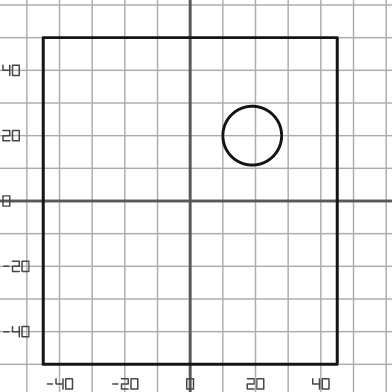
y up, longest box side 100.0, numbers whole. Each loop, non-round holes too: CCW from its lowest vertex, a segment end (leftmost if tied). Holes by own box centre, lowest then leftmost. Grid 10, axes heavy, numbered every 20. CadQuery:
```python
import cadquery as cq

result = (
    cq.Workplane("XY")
    .moveTo(-45.0, -50.0)
    .lineTo(45.0, -50.0)
    .lineTo(45.0, 50.0)
    .lineTo(-45.0, 50.0)
    .close()
    .moveTo(19.0, 20.0)
    .circle(9.0)
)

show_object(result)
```